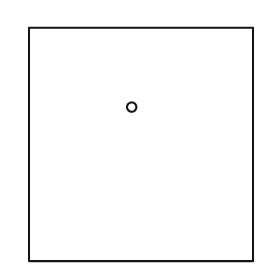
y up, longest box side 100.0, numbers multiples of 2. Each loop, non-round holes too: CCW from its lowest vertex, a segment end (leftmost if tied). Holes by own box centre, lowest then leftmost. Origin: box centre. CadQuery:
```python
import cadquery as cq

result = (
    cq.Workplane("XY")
    .moveTo(-48.0, -50.0)
    .lineTo(48.0, -50.0)
    .lineTo(48.0, 50.0)
    .lineTo(-48.0, 50.0)
    .close()
    .moveTo(-4.0, 16.0)
    .circle(2.0)
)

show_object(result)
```